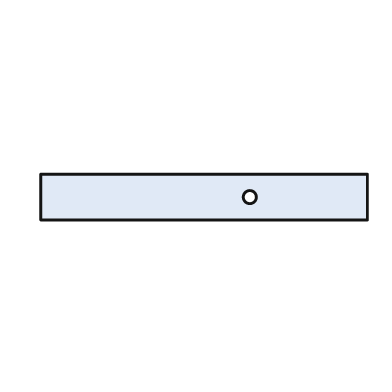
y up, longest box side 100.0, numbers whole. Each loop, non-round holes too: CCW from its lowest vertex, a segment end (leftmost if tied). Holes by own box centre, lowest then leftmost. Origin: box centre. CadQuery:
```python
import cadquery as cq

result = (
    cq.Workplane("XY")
    .moveTo(-50.0, -7.0)
    .lineTo(50.0, -7.0)
    .lineTo(50.0, 7.0)
    .lineTo(-50.0, 7.0)
    .close()
    .moveTo(14.0, 0.0)
    .circle(2.0)
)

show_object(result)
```